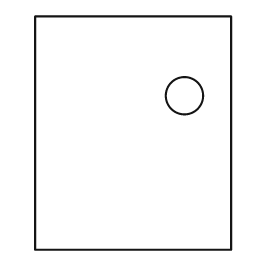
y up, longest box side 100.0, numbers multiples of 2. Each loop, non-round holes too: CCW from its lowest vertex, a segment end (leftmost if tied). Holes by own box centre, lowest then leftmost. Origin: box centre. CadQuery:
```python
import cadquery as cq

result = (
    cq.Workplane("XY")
    .moveTo(-42.0, -50.0)
    .lineTo(42.0, -50.0)
    .lineTo(42.0, 50.0)
    .lineTo(-42.0, 50.0)
    .close()
    .moveTo(22.0, 16.0)
    .circle(8.0)
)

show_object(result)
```